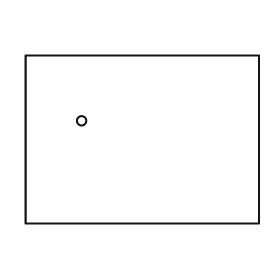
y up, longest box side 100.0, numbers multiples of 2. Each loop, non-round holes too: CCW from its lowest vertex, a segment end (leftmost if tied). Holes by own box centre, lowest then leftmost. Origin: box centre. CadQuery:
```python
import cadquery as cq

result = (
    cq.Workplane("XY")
    .moveTo(-50.0, -36.0)
    .lineTo(50.0, -36.0)
    .lineTo(50.0, 36.0)
    .lineTo(-50.0, 36.0)
    .close()
    .moveTo(-26.0, 8.0)
    .circle(2.0)
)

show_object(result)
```